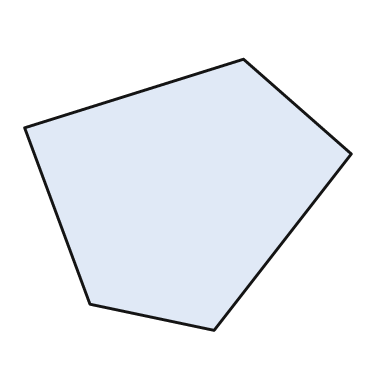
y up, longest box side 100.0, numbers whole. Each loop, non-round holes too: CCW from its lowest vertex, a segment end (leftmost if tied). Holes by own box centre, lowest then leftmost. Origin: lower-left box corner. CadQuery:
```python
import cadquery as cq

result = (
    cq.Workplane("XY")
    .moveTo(58.0, 0.0)
    .lineTo(100.0, 54.0)
    .lineTo(67.0, 83.0)
    .lineTo(0.0, 62.0)
    .lineTo(20.0, 8.0)
    .close()
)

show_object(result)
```